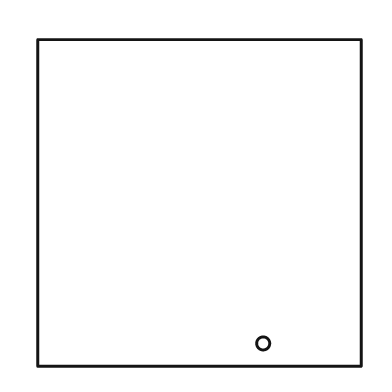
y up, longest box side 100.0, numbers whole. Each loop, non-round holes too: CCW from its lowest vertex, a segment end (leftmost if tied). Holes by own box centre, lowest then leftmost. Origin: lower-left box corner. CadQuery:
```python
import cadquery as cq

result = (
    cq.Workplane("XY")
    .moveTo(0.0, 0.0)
    .lineTo(99.0, 0.0)
    .lineTo(99.0, 100.0)
    .lineTo(0.0, 100.0)
    .close()
    .moveTo(69.0, 7.0)
    .circle(2.0)
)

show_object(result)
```